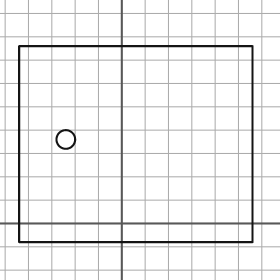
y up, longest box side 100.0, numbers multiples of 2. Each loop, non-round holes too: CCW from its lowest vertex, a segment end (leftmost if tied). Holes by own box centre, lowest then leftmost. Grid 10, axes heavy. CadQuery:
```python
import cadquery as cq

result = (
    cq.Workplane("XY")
    .moveTo(-44.0, -8.0)
    .lineTo(56.0, -8.0)
    .lineTo(56.0, 76.0)
    .lineTo(-44.0, 76.0)
    .close()
    .moveTo(-24.0, 36.0)
    .circle(4.0)
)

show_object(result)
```